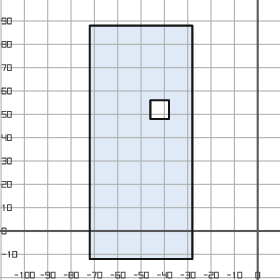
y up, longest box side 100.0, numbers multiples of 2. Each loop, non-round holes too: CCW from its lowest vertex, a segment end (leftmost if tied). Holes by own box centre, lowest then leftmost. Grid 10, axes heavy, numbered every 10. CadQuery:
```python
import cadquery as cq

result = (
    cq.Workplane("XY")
    .moveTo(-72.0, -12.0)
    .lineTo(-28.0, -12.0)
    .lineTo(-28.0, 88.0)
    .lineTo(-72.0, 88.0)
    .close()
    .moveTo(-46.0, 48.0)
    .lineTo(-38.0, 48.0)
    .lineTo(-38.0, 56.0)
    .lineTo(-46.0, 56.0)
    .close()
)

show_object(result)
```